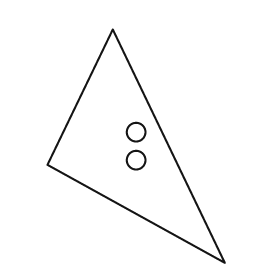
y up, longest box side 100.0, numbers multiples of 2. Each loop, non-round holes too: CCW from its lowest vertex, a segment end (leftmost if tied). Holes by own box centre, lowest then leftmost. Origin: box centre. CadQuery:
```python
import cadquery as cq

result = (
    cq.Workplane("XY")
    .moveTo(38.0, -50.0)
    .lineTo(-10.0, 50.0)
    .lineTo(-38.0, -8.0)
    .close()
    .moveTo(0.0, -6.0)
    .circle(4.0)
    .moveTo(0.0, 6.0)
    .circle(4.0)
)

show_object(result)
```